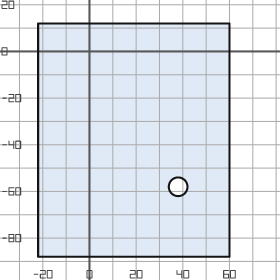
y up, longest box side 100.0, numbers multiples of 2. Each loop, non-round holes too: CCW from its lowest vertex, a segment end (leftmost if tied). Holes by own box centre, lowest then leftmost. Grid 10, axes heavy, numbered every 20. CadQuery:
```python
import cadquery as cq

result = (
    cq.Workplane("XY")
    .moveTo(-22.0, -88.0)
    .lineTo(60.0, -88.0)
    .lineTo(60.0, 12.0)
    .lineTo(-22.0, 12.0)
    .close()
    .moveTo(38.0, -58.0)
    .circle(4.0)
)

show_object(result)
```